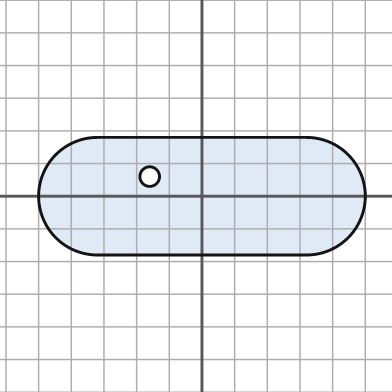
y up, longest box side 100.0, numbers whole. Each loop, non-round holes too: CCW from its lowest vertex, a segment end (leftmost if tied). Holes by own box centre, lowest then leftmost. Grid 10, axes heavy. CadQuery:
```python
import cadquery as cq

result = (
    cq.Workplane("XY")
    .moveTo(-32.0, -18.0)
    .lineTo(32.0, -18.0)
    .threePointArc((50.0, 0.0), (32.0, 18.0))
    .lineTo(-32.0, 18.0)
    .threePointArc((-50.0, 0.0), (-32.0, -18.0))
    .close()
    .moveTo(-16.0, 6.0)
    .circle(3.0)
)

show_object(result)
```